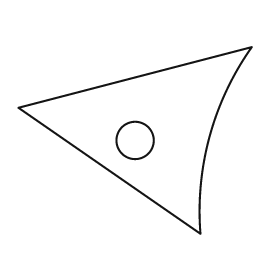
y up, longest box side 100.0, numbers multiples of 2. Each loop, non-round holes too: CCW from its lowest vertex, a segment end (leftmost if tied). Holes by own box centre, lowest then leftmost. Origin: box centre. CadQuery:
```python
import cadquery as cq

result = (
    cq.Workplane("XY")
    .moveTo(28.0, -40.0)
    .threePointArc((32.0, 2.0), (50.0, 40.0))
    .lineTo(-50.0, 14.0)
    .close()
    .moveTo(0.0, 0.0)
    .circle(8.0)
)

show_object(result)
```